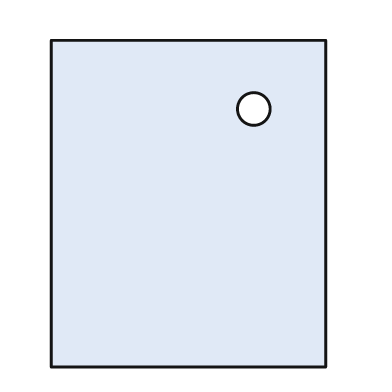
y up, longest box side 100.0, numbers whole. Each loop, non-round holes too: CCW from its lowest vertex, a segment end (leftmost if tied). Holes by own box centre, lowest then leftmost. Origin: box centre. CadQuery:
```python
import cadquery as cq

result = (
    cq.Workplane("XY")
    .moveTo(-42.0, -50.0)
    .lineTo(42.0, -50.0)
    .lineTo(42.0, 50.0)
    .lineTo(-42.0, 50.0)
    .close()
    .moveTo(20.0, 29.0)
    .circle(5.0)
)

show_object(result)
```